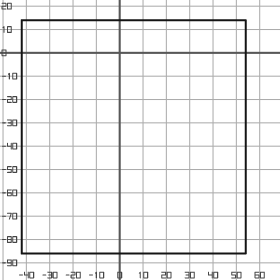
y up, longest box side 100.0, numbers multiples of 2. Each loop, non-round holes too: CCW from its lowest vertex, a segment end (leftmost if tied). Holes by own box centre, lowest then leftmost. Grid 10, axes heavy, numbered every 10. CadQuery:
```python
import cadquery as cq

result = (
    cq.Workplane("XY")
    .moveTo(-42.0, -86.0)
    .lineTo(54.0, -86.0)
    .lineTo(54.0, 14.0)
    .lineTo(-42.0, 14.0)
    .close()
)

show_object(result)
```